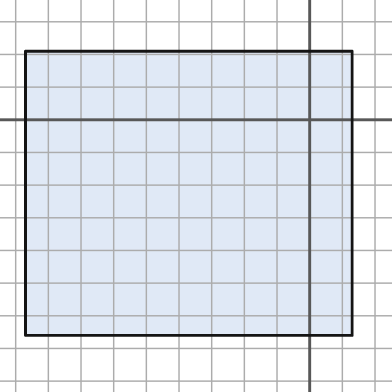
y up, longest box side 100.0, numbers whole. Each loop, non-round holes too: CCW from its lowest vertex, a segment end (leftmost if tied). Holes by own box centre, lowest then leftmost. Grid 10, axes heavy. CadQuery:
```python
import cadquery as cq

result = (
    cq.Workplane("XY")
    .moveTo(-87.0, -66.0)
    .lineTo(13.0, -66.0)
    .lineTo(13.0, 21.0)
    .lineTo(-87.0, 21.0)
    .close()
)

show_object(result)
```